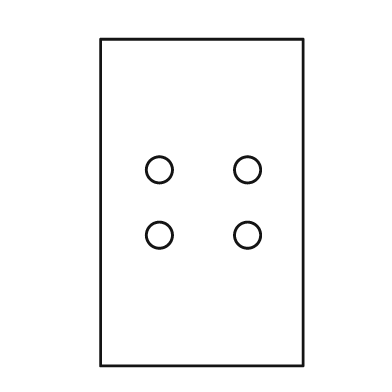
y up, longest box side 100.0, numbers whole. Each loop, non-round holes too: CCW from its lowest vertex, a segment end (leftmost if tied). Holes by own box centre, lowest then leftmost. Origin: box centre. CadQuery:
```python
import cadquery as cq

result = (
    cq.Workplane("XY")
    .moveTo(-31.0, -50.0)
    .lineTo(31.0, -50.0)
    .lineTo(31.0, 50.0)
    .lineTo(-31.0, 50.0)
    .close()
    .moveTo(-13.0, -10.0)
    .circle(4.0)
    .moveTo(14.0, -10.0)
    .circle(4.0)
    .moveTo(-13.0, 10.0)
    .circle(4.0)
    .moveTo(14.0, 10.0)
    .circle(4.0)
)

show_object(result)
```